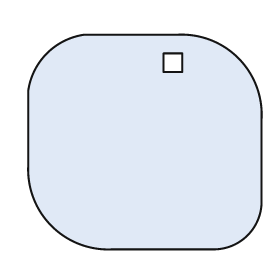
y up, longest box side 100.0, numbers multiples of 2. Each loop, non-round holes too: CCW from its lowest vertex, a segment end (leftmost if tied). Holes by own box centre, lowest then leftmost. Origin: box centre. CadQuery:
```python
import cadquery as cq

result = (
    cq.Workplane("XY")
    .moveTo(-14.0, -46.0)
    .lineTo(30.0, -46.0)
    .threePointArc((44.0, -40.0), (50.0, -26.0))
    .lineTo(50.0, 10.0)
    .threePointArc((40.0, 36.0), (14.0, 46.0))
    .lineTo(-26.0, 46.0)
    .threePointArc((-42.0, 38.0), (-50.0, 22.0))
    .lineTo(-50.0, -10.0)
    .threePointArc((-40.0, -36.0), (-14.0, -46.0))
    .close()
    .moveTo(8.0, 30.0)
    .lineTo(16.0, 30.0)
    .lineTo(16.0, 38.0)
    .lineTo(8.0, 38.0)
    .close()
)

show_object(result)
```